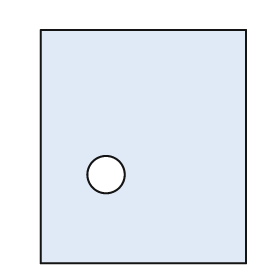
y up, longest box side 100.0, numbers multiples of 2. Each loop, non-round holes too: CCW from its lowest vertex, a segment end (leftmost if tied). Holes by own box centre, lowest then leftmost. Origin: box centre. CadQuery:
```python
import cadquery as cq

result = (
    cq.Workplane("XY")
    .moveTo(-44.0, -50.0)
    .lineTo(44.0, -50.0)
    .lineTo(44.0, 50.0)
    .lineTo(-44.0, 50.0)
    .close()
    .moveTo(-16.0, -12.0)
    .circle(8.0)
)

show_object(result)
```